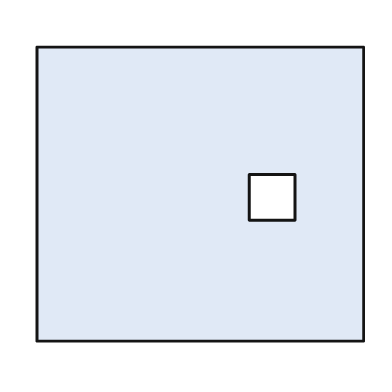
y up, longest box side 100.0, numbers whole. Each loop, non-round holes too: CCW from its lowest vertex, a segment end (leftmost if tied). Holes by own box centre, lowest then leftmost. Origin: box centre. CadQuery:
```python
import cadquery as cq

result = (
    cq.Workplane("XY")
    .moveTo(-50.0, -45.0)
    .lineTo(50.0, -45.0)
    .lineTo(50.0, 45.0)
    .lineTo(-50.0, 45.0)
    .close()
    .moveTo(15.0, -8.0)
    .lineTo(29.0, -8.0)
    .lineTo(29.0, 6.0)
    .lineTo(15.0, 6.0)
    .close()
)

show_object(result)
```